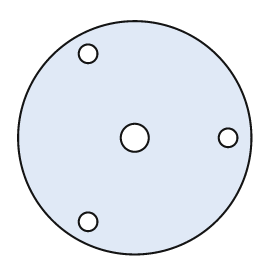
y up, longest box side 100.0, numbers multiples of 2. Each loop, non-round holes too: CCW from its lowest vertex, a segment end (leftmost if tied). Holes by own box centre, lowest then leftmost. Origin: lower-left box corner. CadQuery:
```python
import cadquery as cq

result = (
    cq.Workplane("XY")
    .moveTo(50.0, 50.0)
    .circle(50.0)
    .moveTo(30.0, 14.0)
    .circle(4.0)
    .moveTo(50.0, 50.0)
    .circle(6.0)
    .moveTo(90.0, 50.0)
    .circle(4.0)
    .moveTo(30.0, 86.0)
    .circle(4.0)
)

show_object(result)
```